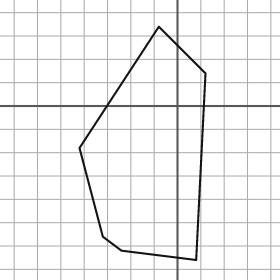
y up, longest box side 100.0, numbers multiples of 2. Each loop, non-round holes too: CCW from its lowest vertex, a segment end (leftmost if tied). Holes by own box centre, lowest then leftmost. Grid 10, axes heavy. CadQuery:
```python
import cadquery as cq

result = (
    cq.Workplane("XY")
    .moveTo(8.0, -66.0)
    .lineTo(12.0, 14.0)
    .lineTo(-8.0, 34.0)
    .lineTo(-42.0, -18.0)
    .lineTo(-32.0, -56.0)
    .lineTo(-24.0, -62.0)
    .close()
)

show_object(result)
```